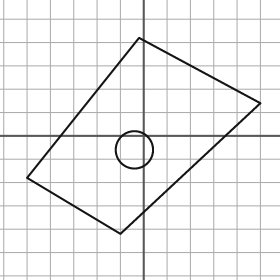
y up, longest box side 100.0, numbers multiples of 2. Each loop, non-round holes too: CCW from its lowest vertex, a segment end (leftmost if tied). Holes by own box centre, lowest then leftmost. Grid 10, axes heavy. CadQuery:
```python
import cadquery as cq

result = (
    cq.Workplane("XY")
    .moveTo(-10.0, -42.0)
    .lineTo(50.0, 14.0)
    .lineTo(-2.0, 42.0)
    .lineTo(-50.0, -18.0)
    .close()
    .moveTo(-4.0, -6.0)
    .circle(8.0)
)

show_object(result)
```